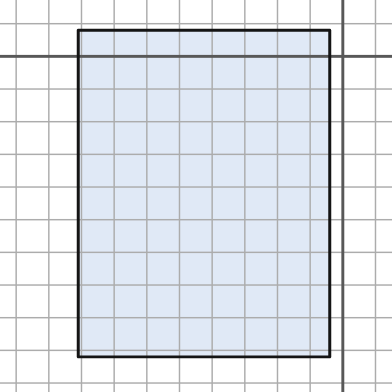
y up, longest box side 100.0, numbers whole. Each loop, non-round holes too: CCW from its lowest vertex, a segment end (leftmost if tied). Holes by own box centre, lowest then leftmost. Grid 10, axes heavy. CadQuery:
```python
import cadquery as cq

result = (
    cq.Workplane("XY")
    .moveTo(-81.0, -92.0)
    .lineTo(-4.0, -92.0)
    .lineTo(-4.0, 8.0)
    .lineTo(-81.0, 8.0)
    .close()
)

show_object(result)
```